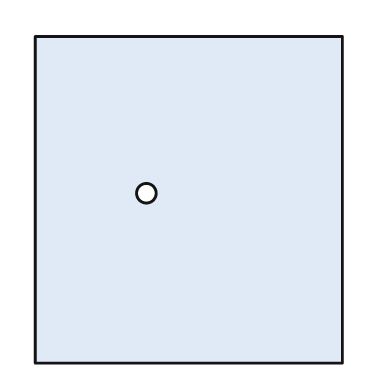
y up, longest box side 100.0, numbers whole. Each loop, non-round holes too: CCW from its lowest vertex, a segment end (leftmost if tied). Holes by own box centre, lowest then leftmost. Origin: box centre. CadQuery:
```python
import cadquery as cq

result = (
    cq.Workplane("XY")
    .moveTo(-47.0, -50.0)
    .lineTo(47.0, -50.0)
    .lineTo(47.0, 50.0)
    .lineTo(-47.0, 50.0)
    .close()
    .moveTo(-13.0, 2.0)
    .circle(3.0)
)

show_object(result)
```